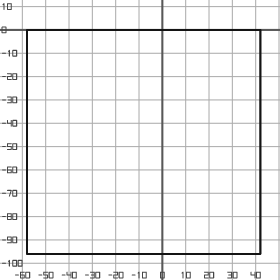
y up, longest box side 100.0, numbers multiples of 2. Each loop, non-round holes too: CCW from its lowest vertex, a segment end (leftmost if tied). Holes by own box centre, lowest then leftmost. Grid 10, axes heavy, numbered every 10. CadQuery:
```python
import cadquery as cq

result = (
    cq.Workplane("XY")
    .moveTo(-58.0, -96.0)
    .lineTo(42.0, -96.0)
    .lineTo(42.0, 0.0)
    .lineTo(-58.0, 0.0)
    .close()
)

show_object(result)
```